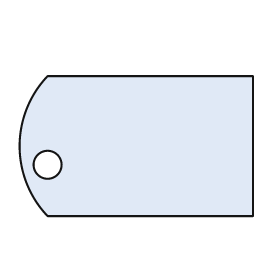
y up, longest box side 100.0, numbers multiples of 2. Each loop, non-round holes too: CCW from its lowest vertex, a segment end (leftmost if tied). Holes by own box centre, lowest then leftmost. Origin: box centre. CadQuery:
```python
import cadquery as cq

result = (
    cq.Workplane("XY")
    .moveTo(-38.0, -30.0)
    .lineTo(50.0, -30.0)
    .lineTo(50.0, 30.0)
    .lineTo(-38.0, 30.0)
    .threePointArc((-50.0, 0.0), (-38.0, -30.0))
    .close()
    .moveTo(-38.0, -8.0)
    .circle(6.0)
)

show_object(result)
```